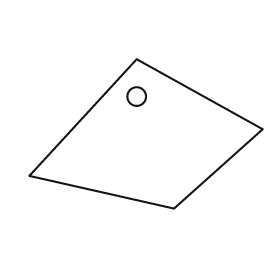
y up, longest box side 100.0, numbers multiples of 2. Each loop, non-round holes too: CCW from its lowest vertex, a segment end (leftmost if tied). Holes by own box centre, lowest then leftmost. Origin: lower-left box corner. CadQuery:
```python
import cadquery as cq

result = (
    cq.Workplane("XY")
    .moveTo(62.0, 0.0)
    .lineTo(100.0, 34.0)
    .lineTo(46.0, 64.0)
    .lineTo(0.0, 14.0)
    .close()
    .moveTo(46.0, 48.0)
    .circle(4.0)
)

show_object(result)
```